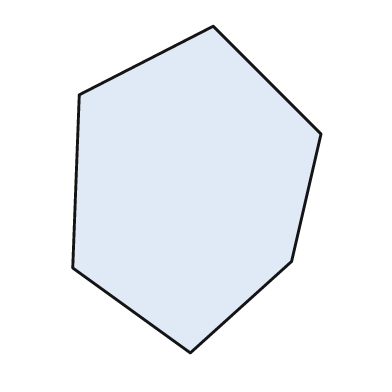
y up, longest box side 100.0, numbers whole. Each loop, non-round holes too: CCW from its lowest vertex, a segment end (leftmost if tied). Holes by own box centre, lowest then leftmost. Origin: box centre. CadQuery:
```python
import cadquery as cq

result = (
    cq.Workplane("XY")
    .moveTo(-2.0, -50.0)
    .lineTo(29.0, -22.0)
    .lineTo(38.0, 17.0)
    .lineTo(5.0, 50.0)
    .lineTo(-36.0, 29.0)
    .lineTo(-38.0, -24.0)
    .close()
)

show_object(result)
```